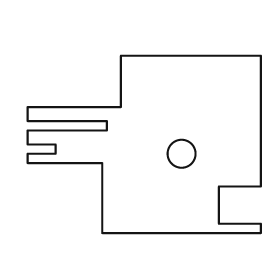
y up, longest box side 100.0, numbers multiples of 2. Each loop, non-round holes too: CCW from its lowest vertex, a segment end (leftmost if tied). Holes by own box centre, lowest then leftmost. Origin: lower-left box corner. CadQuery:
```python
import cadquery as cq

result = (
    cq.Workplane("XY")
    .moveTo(32.0, 0.0)
    .lineTo(100.0, 0.0)
    .lineTo(100.0, 4.0)
    .lineTo(82.0, 4.0)
    .lineTo(82.0, 20.0)
    .lineTo(100.0, 20.0)
    .lineTo(100.0, 76.0)
    .lineTo(40.0, 76.0)
    .lineTo(40.0, 54.0)
    .lineTo(0.0, 54.0)
    .lineTo(0.0, 48.0)
    .lineTo(34.0, 48.0)
    .lineTo(34.0, 44.0)
    .lineTo(0.0, 44.0)
    .lineTo(0.0, 38.0)
    .lineTo(12.0, 38.0)
    .lineTo(12.0, 34.0)
    .lineTo(0.0, 34.0)
    .lineTo(0.0, 30.0)
    .lineTo(32.0, 30.0)
    .close()
    .moveTo(66.0, 34.0)
    .circle(6.0)
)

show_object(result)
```